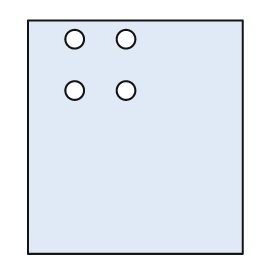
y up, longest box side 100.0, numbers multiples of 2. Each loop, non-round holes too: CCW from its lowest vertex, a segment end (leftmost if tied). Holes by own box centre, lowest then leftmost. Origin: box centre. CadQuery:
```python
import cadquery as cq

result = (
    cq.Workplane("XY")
    .moveTo(-46.0, -50.0)
    .lineTo(46.0, -50.0)
    .lineTo(46.0, 50.0)
    .lineTo(-46.0, 50.0)
    .close()
    .moveTo(-26.0, 20.0)
    .circle(4.0)
    .moveTo(-4.0, 20.0)
    .circle(4.0)
    .moveTo(-26.0, 42.0)
    .circle(4.0)
    .moveTo(-4.0, 42.0)
    .circle(4.0)
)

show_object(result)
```